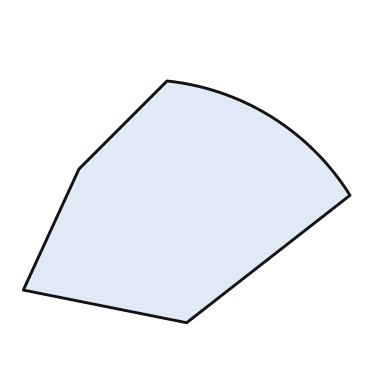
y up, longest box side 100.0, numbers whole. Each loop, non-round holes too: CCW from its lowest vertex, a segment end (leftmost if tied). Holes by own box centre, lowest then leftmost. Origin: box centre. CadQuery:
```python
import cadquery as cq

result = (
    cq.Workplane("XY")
    .moveTo(0.0, -37.0)
    .lineTo(50.0, 2.0)
    .threePointArc((26.0, 26.0), (-6.0, 37.0))
    .lineTo(-33.0, 10.0)
    .lineTo(-50.0, -27.0)
    .close()
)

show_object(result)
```